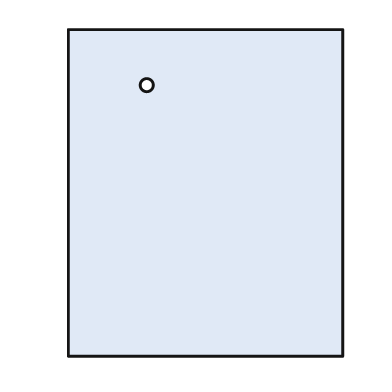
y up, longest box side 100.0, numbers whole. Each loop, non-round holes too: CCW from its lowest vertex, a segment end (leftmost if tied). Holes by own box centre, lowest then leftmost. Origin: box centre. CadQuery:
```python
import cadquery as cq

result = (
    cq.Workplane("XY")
    .moveTo(-42.0, -50.0)
    .lineTo(42.0, -50.0)
    .lineTo(42.0, 50.0)
    .lineTo(-42.0, 50.0)
    .close()
    .moveTo(-18.0, 33.0)
    .circle(2.0)
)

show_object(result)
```